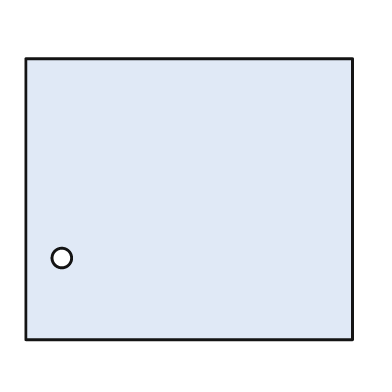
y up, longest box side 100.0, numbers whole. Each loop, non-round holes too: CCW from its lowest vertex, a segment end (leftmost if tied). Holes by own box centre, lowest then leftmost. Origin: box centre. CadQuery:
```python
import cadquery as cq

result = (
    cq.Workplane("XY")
    .moveTo(-50.0, -43.0)
    .lineTo(50.0, -43.0)
    .lineTo(50.0, 43.0)
    .lineTo(-50.0, 43.0)
    .close()
    .moveTo(-39.0, -18.0)
    .circle(3.0)
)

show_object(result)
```